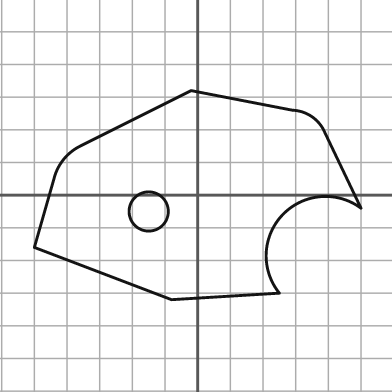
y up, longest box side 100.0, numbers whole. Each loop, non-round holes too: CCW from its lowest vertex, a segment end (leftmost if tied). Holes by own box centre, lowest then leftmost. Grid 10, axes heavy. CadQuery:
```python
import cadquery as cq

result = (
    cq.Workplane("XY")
    .moveTo(-8.0, -32.0)
    .lineTo(25.0, -30.0)
    .threePointArc((26.0, -6.0), (50.0, -4.0))
    .lineTo(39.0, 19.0)
    .threePointArc((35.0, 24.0), (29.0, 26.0))
    .lineTo(-2.0, 32.0)
    .lineTo(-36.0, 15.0)
    .threePointArc((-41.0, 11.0), (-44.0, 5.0))
    .lineTo(-50.0, -16.0)
    .close()
    .moveTo(-15.0, -5.0)
    .circle(6.0)
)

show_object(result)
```